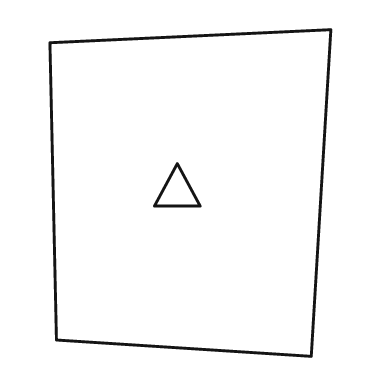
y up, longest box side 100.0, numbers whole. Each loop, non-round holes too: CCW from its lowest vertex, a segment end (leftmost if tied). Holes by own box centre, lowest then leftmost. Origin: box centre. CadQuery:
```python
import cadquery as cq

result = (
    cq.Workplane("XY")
    .moveTo(37.0, -50.0)
    .lineTo(43.0, 50.0)
    .lineTo(-43.0, 46.0)
    .lineTo(-41.0, -45.0)
    .close()
    .moveTo(-11.0, -4.0)
    .lineTo(3.0, -4.0)
    .lineTo(-4.0, 9.0)
    .close()
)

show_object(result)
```